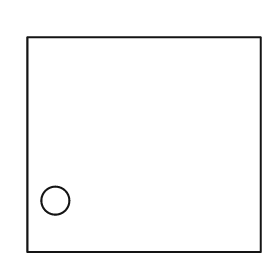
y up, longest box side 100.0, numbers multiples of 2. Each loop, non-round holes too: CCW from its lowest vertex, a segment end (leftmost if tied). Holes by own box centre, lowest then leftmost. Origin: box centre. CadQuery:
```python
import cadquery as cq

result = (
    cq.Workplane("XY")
    .moveTo(-50.0, -46.0)
    .lineTo(50.0, -46.0)
    .lineTo(50.0, 46.0)
    .lineTo(-50.0, 46.0)
    .close()
    .moveTo(-38.0, -24.0)
    .circle(6.0)
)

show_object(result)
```